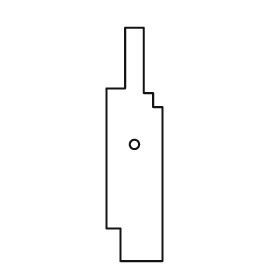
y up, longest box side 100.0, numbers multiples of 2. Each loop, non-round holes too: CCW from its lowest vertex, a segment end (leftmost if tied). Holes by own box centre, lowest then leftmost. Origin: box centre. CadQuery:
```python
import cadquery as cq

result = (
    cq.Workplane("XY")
    .moveTo(-6.0, -50.0)
    .lineTo(12.0, -50.0)
    .lineTo(12.0, 16.0)
    .lineTo(8.0, 16.0)
    .lineTo(8.0, 22.0)
    .lineTo(4.0, 22.0)
    .lineTo(4.0, 50.0)
    .lineTo(-4.0, 50.0)
    .lineTo(-4.0, 24.0)
    .lineTo(-12.0, 24.0)
    .lineTo(-12.0, -36.0)
    .lineTo(-6.0, -36.0)
    .close()
    .moveTo(0.0, 0.0)
    .circle(2.0)
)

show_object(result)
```